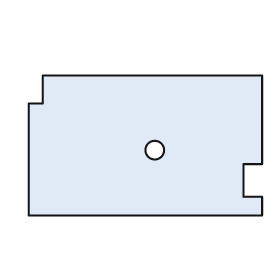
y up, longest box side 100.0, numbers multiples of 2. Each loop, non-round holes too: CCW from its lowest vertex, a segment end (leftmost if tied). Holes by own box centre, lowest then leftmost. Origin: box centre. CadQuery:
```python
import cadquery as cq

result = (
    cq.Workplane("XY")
    .moveTo(-50.0, -30.0)
    .lineTo(50.0, -30.0)
    .lineTo(50.0, -22.0)
    .lineTo(42.0, -22.0)
    .lineTo(42.0, -8.0)
    .lineTo(50.0, -8.0)
    .lineTo(50.0, 30.0)
    .lineTo(-44.0, 30.0)
    .lineTo(-44.0, 18.0)
    .lineTo(-50.0, 18.0)
    .close()
    .moveTo(4.0, -2.0)
    .circle(4.0)
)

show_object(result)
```